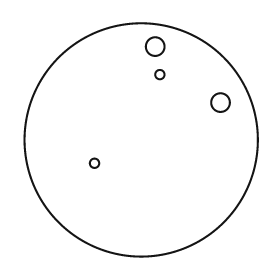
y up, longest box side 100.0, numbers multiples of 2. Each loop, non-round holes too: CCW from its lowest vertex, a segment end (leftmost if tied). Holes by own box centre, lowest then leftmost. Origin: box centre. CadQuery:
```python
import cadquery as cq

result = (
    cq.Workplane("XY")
    .moveTo(0.0, 0.0)
    .circle(50.0)
    .moveTo(-20.0, -10.0)
    .circle(2.0)
    .moveTo(34.0, 16.0)
    .circle(4.0)
    .moveTo(8.0, 28.0)
    .circle(2.0)
    .moveTo(6.0, 40.0)
    .circle(4.0)
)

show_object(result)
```